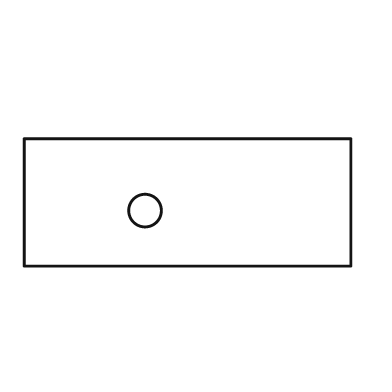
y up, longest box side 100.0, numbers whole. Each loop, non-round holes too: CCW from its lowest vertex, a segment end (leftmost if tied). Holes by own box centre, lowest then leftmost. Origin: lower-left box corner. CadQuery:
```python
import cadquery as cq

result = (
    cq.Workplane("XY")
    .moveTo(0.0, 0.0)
    .lineTo(100.0, 0.0)
    .lineTo(100.0, 39.0)
    .lineTo(0.0, 39.0)
    .close()
    .moveTo(37.0, 17.0)
    .circle(5.0)
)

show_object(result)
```